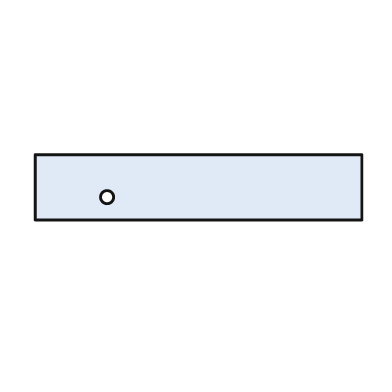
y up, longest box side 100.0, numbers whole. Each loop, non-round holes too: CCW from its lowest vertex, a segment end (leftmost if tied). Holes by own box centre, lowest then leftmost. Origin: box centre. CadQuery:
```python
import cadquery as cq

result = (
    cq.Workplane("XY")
    .moveTo(-50.0, -10.0)
    .lineTo(50.0, -10.0)
    .lineTo(50.0, 10.0)
    .lineTo(-50.0, 10.0)
    .close()
    .moveTo(-28.0, -3.0)
    .circle(2.0)
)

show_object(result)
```